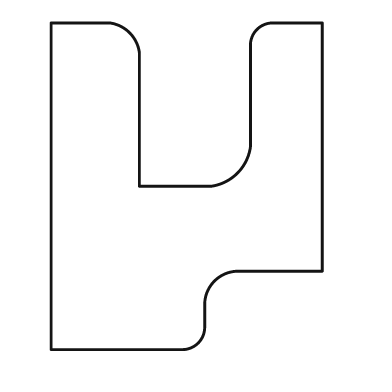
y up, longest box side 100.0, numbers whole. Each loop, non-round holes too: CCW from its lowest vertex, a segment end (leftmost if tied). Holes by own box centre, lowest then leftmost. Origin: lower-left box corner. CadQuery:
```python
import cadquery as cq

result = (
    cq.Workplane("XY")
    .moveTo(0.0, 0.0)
    .lineTo(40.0, 0.0)
    .threePointArc((45.0, 2.0), (47.0, 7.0))
    .lineTo(47.0, 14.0)
    .threePointArc((50.0, 21.0), (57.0, 24.0))
    .lineTo(83.0, 24.0)
    .lineTo(83.0, 100.0)
    .lineTo(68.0, 100.0)
    .threePointArc((63.0, 98.0), (61.0, 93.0))
    .lineTo(61.0, 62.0)
    .threePointArc((57.0, 54.0), (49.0, 50.0))
    .lineTo(27.0, 50.0)
    .lineTo(27.0, 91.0)
    .threePointArc((24.0, 97.0), (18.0, 100.0))
    .lineTo(0.0, 100.0)
    .close()
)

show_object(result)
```